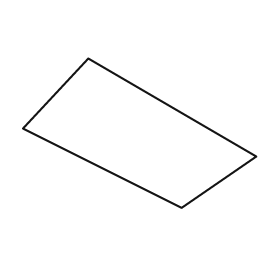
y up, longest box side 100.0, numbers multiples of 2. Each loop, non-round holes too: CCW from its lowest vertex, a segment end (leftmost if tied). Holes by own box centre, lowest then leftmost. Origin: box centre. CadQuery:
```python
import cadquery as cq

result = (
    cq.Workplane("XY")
    .moveTo(18.0, -32.0)
    .lineTo(50.0, -10.0)
    .lineTo(-22.0, 32.0)
    .lineTo(-50.0, 2.0)
    .close()
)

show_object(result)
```